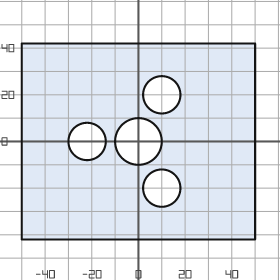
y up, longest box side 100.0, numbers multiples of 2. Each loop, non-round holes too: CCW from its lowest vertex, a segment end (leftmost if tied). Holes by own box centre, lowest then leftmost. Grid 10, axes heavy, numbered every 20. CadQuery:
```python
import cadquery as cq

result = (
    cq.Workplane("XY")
    .moveTo(-50.0, -42.0)
    .lineTo(50.0, -42.0)
    .lineTo(50.0, 42.0)
    .lineTo(-50.0, 42.0)
    .close()
    .moveTo(10.0, -20.0)
    .circle(8.0)
    .moveTo(-22.0, 0.0)
    .circle(8.0)
    .moveTo(0.0, 0.0)
    .circle(10.0)
    .moveTo(10.0, 20.0)
    .circle(8.0)
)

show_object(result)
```